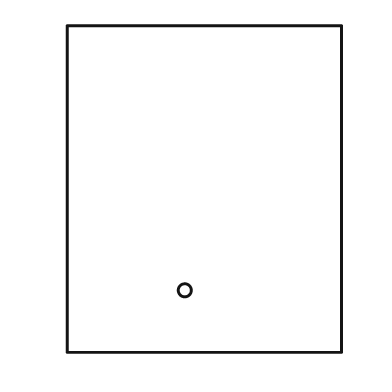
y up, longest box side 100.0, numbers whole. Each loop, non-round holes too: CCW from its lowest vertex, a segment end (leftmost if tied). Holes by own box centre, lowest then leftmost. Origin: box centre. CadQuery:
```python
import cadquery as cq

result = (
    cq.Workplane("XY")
    .moveTo(-42.0, -50.0)
    .lineTo(42.0, -50.0)
    .lineTo(42.0, 50.0)
    .lineTo(-42.0, 50.0)
    .close()
    .moveTo(-6.0, -31.0)
    .circle(2.0)
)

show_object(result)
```